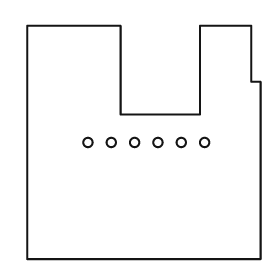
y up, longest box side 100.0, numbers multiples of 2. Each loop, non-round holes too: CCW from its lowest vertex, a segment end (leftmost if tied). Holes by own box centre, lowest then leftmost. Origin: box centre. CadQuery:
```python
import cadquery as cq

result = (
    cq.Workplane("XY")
    .moveTo(-50.0, -50.0)
    .lineTo(50.0, -50.0)
    .lineTo(50.0, 26.0)
    .lineTo(46.0, 26.0)
    .lineTo(46.0, 50.0)
    .lineTo(24.0, 50.0)
    .lineTo(24.0, 12.0)
    .lineTo(-10.0, 12.0)
    .lineTo(-10.0, 50.0)
    .lineTo(-50.0, 50.0)
    .close()
    .moveTo(-24.0, 0.0)
    .circle(2.0)
    .moveTo(-14.0, 0.0)
    .circle(2.0)
    .moveTo(-4.0, 0.0)
    .circle(2.0)
    .moveTo(6.0, 0.0)
    .circle(2.0)
    .moveTo(16.0, 0.0)
    .circle(2.0)
    .moveTo(26.0, 0.0)
    .circle(2.0)
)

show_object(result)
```